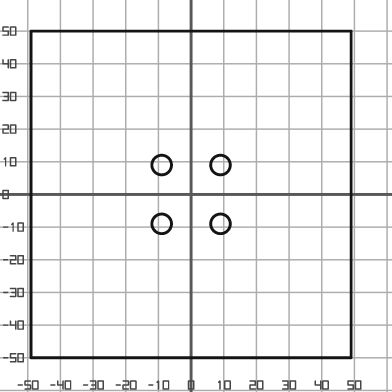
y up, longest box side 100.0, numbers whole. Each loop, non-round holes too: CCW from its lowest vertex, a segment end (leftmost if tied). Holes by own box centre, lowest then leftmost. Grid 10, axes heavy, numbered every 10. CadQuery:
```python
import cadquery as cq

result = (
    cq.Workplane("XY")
    .moveTo(-49.0, -50.0)
    .lineTo(49.0, -50.0)
    .lineTo(49.0, 50.0)
    .lineTo(-49.0, 50.0)
    .close()
    .moveTo(-9.0, -9.0)
    .circle(3.0)
    .moveTo(9.0, -9.0)
    .circle(3.0)
    .moveTo(-9.0, 9.0)
    .circle(3.0)
    .moveTo(9.0, 9.0)
    .circle(3.0)
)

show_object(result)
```